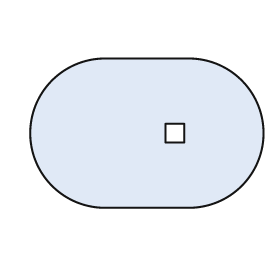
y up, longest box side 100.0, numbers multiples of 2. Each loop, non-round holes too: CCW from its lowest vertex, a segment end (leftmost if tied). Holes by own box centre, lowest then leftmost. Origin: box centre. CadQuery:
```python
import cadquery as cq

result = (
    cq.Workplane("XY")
    .moveTo(-18.0, -32.0)
    .lineTo(18.0, -32.0)
    .threePointArc((50.0, 0.0), (18.0, 32.0))
    .lineTo(-18.0, 32.0)
    .threePointArc((-50.0, 0.0), (-18.0, -32.0))
    .close()
    .moveTo(8.0, -4.0)
    .lineTo(16.0, -4.0)
    .lineTo(16.0, 4.0)
    .lineTo(8.0, 4.0)
    .close()
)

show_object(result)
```